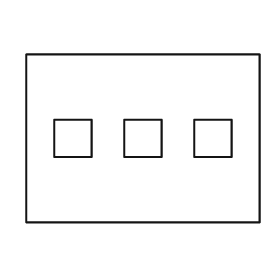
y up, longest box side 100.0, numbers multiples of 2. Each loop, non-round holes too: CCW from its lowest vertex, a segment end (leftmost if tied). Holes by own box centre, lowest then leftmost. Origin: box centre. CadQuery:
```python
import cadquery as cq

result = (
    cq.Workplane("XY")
    .moveTo(-50.0, -36.0)
    .lineTo(50.0, -36.0)
    .lineTo(50.0, 36.0)
    .lineTo(-50.0, 36.0)
    .close()
    .moveTo(-38.0, -8.0)
    .lineTo(-22.0, -8.0)
    .lineTo(-22.0, 8.0)
    .lineTo(-38.0, 8.0)
    .close()
    .moveTo(-8.0, -8.0)
    .lineTo(8.0, -8.0)
    .lineTo(8.0, 8.0)
    .lineTo(-8.0, 8.0)
    .close()
    .moveTo(22.0, -8.0)
    .lineTo(38.0, -8.0)
    .lineTo(38.0, 8.0)
    .lineTo(22.0, 8.0)
    .close()
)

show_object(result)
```